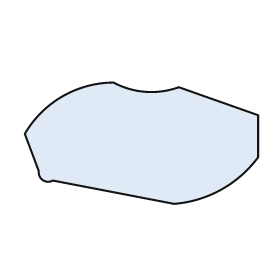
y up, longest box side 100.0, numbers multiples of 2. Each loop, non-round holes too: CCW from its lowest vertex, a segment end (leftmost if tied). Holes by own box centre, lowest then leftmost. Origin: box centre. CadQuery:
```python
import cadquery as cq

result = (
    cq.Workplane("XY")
    .moveTo(14.0, -26.0)
    .threePointArc((34.0, -20.0), (50.0, -6.0))
    .lineTo(50.0, 12.0)
    .lineTo(16.0, 24.0)
    .threePointArc((2.0, 22.0), (-12.0, 26.0))
    .threePointArc((-34.0, 20.0), (-50.0, 4.0))
    .lineTo(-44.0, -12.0)
    .threePointArc((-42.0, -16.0), (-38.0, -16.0))
    .close()
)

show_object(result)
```